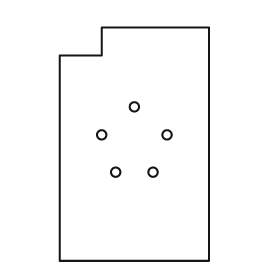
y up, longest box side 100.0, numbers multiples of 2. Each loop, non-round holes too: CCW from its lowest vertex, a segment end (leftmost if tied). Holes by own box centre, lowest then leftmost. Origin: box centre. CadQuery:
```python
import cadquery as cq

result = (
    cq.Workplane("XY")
    .moveTo(-32.0, -50.0)
    .lineTo(32.0, -50.0)
    .lineTo(32.0, 50.0)
    .lineTo(-14.0, 50.0)
    .lineTo(-14.0, 38.0)
    .lineTo(-32.0, 38.0)
    .close()
    .moveTo(-8.0, -12.0)
    .circle(2.0)
    .moveTo(8.0, -12.0)
    .circle(2.0)
    .moveTo(-14.0, 4.0)
    .circle(2.0)
    .moveTo(14.0, 4.0)
    .circle(2.0)
    .moveTo(0.0, 16.0)
    .circle(2.0)
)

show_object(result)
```